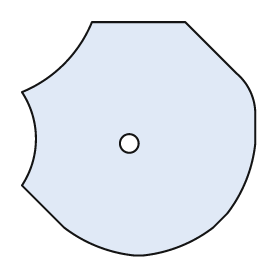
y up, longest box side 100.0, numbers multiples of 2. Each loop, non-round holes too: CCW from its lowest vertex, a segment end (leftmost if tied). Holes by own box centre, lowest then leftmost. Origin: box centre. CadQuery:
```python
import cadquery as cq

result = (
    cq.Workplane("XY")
    .moveTo(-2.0, -50.0)
    .lineTo(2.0, -50.0)
    .threePointArc((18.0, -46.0), (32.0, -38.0))
    .lineTo(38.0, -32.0)
    .threePointArc((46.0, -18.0), (50.0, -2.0))
    .lineTo(50.0, 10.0)
    .threePointArc((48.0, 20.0), (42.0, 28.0))
    .lineTo(20.0, 50.0)
    .lineTo(-20.0, 50.0)
    .threePointArc((-32.0, 32.0), (-50.0, 20.0))
    .threePointArc((-44.0, 0.0), (-50.0, -20.0))
    .lineTo(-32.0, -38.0)
    .threePointArc((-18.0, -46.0), (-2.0, -50.0))
    .close()
    .moveTo(-4.0, -2.0)
    .circle(4.0)
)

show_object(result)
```